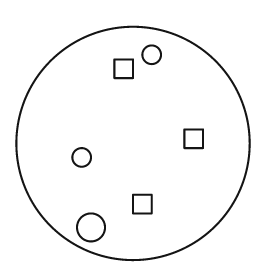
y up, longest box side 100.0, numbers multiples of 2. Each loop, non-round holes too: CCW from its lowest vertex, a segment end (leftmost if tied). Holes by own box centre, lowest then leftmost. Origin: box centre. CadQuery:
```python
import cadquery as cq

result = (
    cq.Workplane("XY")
    .moveTo(0.0, 0.0)
    .circle(50.0)
    .moveTo(-18.0, -36.0)
    .circle(6.0)
    .moveTo(0.0, -30.0)
    .lineTo(8.0, -30.0)
    .lineTo(8.0, -22.0)
    .lineTo(0.0, -22.0)
    .close()
    .moveTo(-22.0, -6.0)
    .circle(4.0)
    .moveTo(22.0, -2.0)
    .lineTo(30.0, -2.0)
    .lineTo(30.0, 6.0)
    .lineTo(22.0, 6.0)
    .close()
    .moveTo(-8.0, 28.0)
    .lineTo(0.0, 28.0)
    .lineTo(0.0, 36.0)
    .lineTo(-8.0, 36.0)
    .close()
    .moveTo(8.0, 38.0)
    .circle(4.0)
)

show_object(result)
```